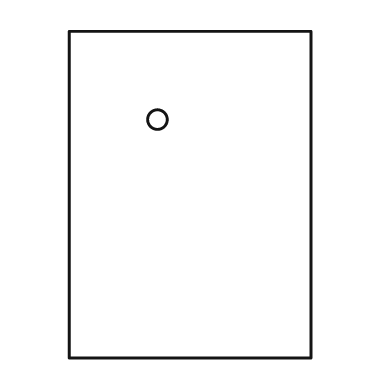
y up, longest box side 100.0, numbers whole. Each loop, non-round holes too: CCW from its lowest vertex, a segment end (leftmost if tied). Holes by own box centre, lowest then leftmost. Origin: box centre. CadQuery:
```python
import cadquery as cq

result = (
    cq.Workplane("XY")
    .moveTo(-37.0, -50.0)
    .lineTo(37.0, -50.0)
    .lineTo(37.0, 50.0)
    .lineTo(-37.0, 50.0)
    .close()
    .moveTo(-10.0, 23.0)
    .circle(3.0)
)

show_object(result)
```